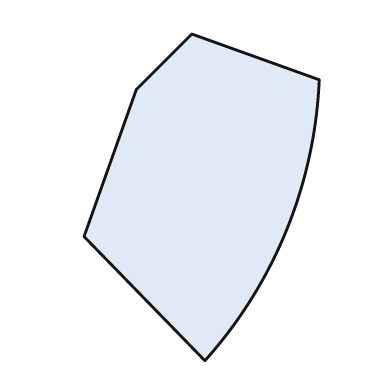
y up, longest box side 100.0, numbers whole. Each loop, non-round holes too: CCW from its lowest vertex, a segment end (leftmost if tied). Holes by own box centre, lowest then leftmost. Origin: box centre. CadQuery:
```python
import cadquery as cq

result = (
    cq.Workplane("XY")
    .moveTo(1.0, -50.0)
    .threePointArc((26.0, -10.0), (36.0, 36.0))
    .lineTo(-3.0, 50.0)
    .lineTo(-20.0, 33.0)
    .lineTo(-36.0, -12.0)
    .close()
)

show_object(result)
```